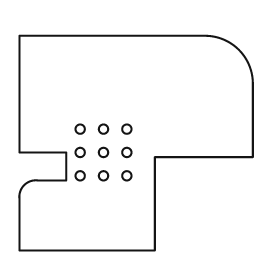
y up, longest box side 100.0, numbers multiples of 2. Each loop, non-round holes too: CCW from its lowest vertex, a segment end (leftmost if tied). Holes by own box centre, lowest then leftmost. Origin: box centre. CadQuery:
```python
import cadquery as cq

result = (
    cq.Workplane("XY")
    .moveTo(-50.0, -46.0)
    .lineTo(8.0, -46.0)
    .lineTo(8.0, -6.0)
    .lineTo(50.0, -6.0)
    .lineTo(50.0, 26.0)
    .threePointArc((44.0, 40.0), (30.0, 46.0))
    .lineTo(-50.0, 46.0)
    .lineTo(-50.0, -4.0)
    .lineTo(-30.0, -4.0)
    .lineTo(-30.0, -16.0)
    .lineTo(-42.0, -16.0)
    .threePointArc((-48.0, -18.0), (-50.0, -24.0))
    .close()
    .moveTo(-24.0, -14.0)
    .circle(2.0)
    .moveTo(-14.0, -14.0)
    .circle(2.0)
    .moveTo(-4.0, -14.0)
    .circle(2.0)
    .moveTo(-24.0, -4.0)
    .circle(2.0)
    .moveTo(-14.0, -4.0)
    .circle(2.0)
    .moveTo(-4.0, -4.0)
    .circle(2.0)
    .moveTo(-24.0, 6.0)
    .circle(2.0)
    .moveTo(-14.0, 6.0)
    .circle(2.0)
    .moveTo(-4.0, 6.0)
    .circle(2.0)
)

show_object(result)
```